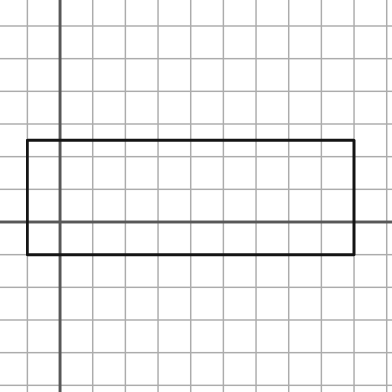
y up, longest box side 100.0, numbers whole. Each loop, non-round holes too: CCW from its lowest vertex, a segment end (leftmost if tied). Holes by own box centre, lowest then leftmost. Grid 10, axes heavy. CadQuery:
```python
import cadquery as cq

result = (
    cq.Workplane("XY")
    .moveTo(-10.0, -10.0)
    .lineTo(90.0, -10.0)
    .lineTo(90.0, 25.0)
    .lineTo(-10.0, 25.0)
    .close()
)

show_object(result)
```